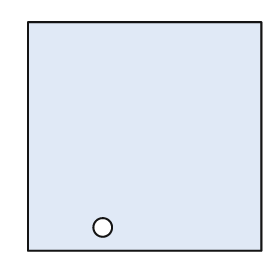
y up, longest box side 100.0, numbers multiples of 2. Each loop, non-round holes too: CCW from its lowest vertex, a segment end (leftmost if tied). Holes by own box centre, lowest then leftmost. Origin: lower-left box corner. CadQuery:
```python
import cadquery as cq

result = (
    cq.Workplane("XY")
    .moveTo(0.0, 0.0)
    .lineTo(100.0, 0.0)
    .lineTo(100.0, 98.0)
    .lineTo(0.0, 98.0)
    .close()
    .moveTo(32.0, 10.0)
    .circle(4.0)
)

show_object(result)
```